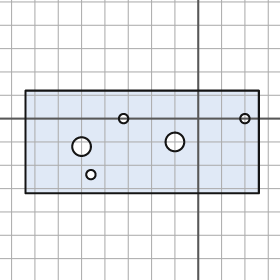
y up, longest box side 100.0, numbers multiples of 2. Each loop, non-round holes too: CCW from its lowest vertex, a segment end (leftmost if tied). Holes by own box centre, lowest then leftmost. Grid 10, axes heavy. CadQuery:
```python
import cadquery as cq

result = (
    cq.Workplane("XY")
    .moveTo(-74.0, -32.0)
    .lineTo(26.0, -32.0)
    .lineTo(26.0, 12.0)
    .lineTo(-74.0, 12.0)
    .close()
    .moveTo(-46.0, -24.0)
    .circle(2.0)
    .moveTo(-50.0, -12.0)
    .circle(4.0)
    .moveTo(-10.0, -10.0)
    .circle(4.0)
    .moveTo(-32.0, 0.0)
    .circle(2.0)
    .moveTo(20.0, 0.0)
    .circle(2.0)
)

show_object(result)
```